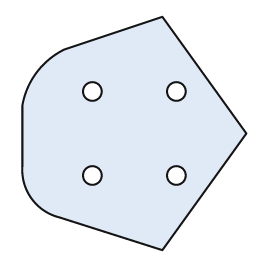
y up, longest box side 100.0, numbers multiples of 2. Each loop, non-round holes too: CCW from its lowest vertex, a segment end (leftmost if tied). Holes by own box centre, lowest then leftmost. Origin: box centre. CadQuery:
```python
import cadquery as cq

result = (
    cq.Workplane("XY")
    .moveTo(12.0, -50.0)
    .lineTo(48.0, 0.0)
    .lineTo(12.0, 50.0)
    .lineTo(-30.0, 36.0)
    .threePointArc((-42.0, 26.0), (-48.0, 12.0))
    .lineTo(-48.0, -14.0)
    .threePointArc((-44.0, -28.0), (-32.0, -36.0))
    .close()
    .moveTo(-18.0, -18.0)
    .circle(4.0)
    .moveTo(18.0, -18.0)
    .circle(4.0)
    .moveTo(-18.0, 18.0)
    .circle(4.0)
    .moveTo(18.0, 18.0)
    .circle(4.0)
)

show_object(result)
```